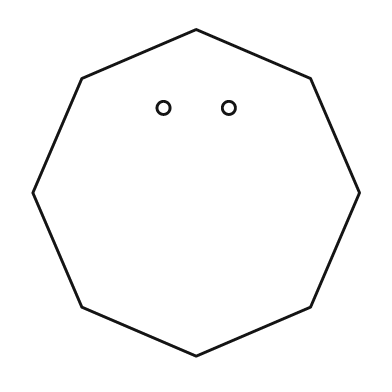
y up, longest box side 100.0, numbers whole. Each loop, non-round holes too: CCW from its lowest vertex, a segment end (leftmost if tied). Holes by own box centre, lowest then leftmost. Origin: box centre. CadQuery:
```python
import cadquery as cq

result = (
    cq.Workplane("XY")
    .moveTo(0.0, -50.0)
    .lineTo(35.0, -35.0)
    .lineTo(50.0, 0.0)
    .lineTo(35.0, 35.0)
    .lineTo(0.0, 50.0)
    .lineTo(-35.0, 35.0)
    .lineTo(-50.0, 0.0)
    .lineTo(-35.0, -35.0)
    .close()
    .moveTo(-10.0, 26.0)
    .circle(2.0)
    .moveTo(10.0, 26.0)
    .circle(2.0)
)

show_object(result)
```